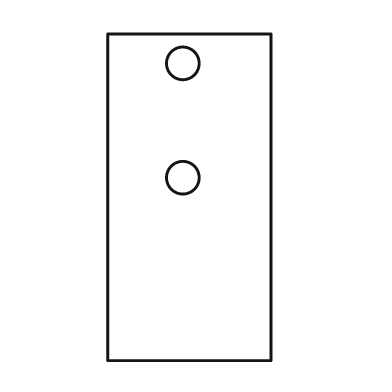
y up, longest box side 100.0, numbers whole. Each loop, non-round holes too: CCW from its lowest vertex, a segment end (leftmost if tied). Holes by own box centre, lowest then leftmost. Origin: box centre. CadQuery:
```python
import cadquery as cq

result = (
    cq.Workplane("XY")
    .moveTo(-25.0, -50.0)
    .lineTo(25.0, -50.0)
    .lineTo(25.0, 50.0)
    .lineTo(-25.0, 50.0)
    .close()
    .moveTo(-2.0, 6.0)
    .circle(5.0)
    .moveTo(-2.0, 41.0)
    .circle(5.0)
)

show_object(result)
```